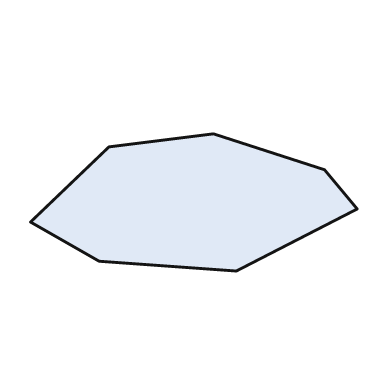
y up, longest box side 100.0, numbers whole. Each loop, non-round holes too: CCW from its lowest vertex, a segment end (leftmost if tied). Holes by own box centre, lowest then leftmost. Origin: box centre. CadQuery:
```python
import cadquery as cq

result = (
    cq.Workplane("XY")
    .moveTo(13.0, -21.0)
    .lineTo(50.0, -2.0)
    .lineTo(40.0, 10.0)
    .lineTo(6.0, 21.0)
    .lineTo(-26.0, 17.0)
    .lineTo(-50.0, -6.0)
    .lineTo(-29.0, -18.0)
    .close()
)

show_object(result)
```